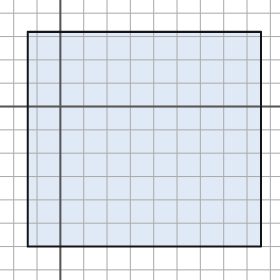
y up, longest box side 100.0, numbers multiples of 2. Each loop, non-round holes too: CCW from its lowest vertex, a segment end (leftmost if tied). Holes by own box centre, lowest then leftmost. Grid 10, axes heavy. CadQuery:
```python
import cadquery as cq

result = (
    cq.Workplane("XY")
    .moveTo(-14.0, -60.0)
    .lineTo(86.0, -60.0)
    .lineTo(86.0, 32.0)
    .lineTo(-14.0, 32.0)
    .close()
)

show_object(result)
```